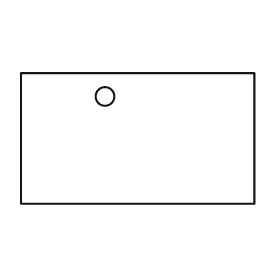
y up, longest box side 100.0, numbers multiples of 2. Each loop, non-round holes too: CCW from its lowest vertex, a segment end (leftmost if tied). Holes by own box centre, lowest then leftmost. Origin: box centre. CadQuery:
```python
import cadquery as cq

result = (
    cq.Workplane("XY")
    .moveTo(-50.0, -28.0)
    .lineTo(50.0, -28.0)
    .lineTo(50.0, 28.0)
    .lineTo(-50.0, 28.0)
    .close()
    .moveTo(-14.0, 18.0)
    .circle(4.0)
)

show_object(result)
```